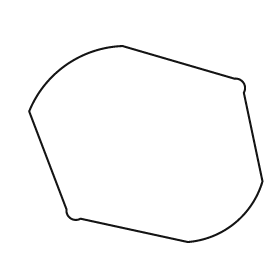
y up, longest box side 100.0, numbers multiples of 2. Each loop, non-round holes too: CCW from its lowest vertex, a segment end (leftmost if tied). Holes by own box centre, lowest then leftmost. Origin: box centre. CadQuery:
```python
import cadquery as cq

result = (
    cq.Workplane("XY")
    .moveTo(18.0, -42.0)
    .threePointArc((38.0, -34.0), (50.0, -16.0))
    .lineTo(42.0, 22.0)
    .threePointArc((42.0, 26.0), (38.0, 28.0))
    .lineTo(-10.0, 42.0)
    .threePointArc((-34.0, 34.0), (-50.0, 14.0))
    .lineTo(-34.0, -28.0)
    .threePointArc((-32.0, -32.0), (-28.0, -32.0))
    .close()
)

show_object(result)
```